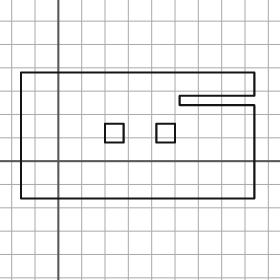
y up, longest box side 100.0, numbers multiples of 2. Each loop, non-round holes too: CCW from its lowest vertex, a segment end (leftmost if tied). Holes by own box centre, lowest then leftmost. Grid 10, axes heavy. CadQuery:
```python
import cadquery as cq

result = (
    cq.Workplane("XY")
    .moveTo(-16.0, -16.0)
    .lineTo(84.0, -16.0)
    .lineTo(84.0, 24.0)
    .lineTo(52.0, 24.0)
    .lineTo(52.0, 28.0)
    .lineTo(84.0, 28.0)
    .lineTo(84.0, 38.0)
    .lineTo(-16.0, 38.0)
    .close()
    .moveTo(20.0, 8.0)
    .lineTo(28.0, 8.0)
    .lineTo(28.0, 16.0)
    .lineTo(20.0, 16.0)
    .close()
    .moveTo(42.0, 8.0)
    .lineTo(50.0, 8.0)
    .lineTo(50.0, 16.0)
    .lineTo(42.0, 16.0)
    .close()
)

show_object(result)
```